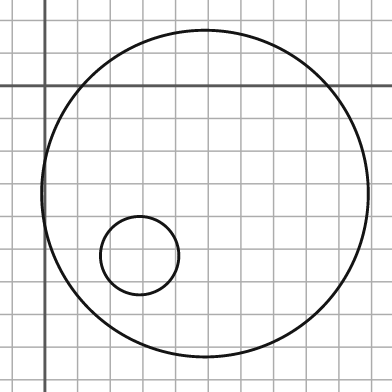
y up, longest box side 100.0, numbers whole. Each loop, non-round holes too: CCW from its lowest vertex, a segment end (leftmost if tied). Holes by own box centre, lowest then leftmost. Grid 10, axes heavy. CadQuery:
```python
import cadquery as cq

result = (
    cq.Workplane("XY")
    .moveTo(49.0, -33.0)
    .circle(50.0)
    .moveTo(29.0, -52.0)
    .circle(12.0)
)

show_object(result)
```